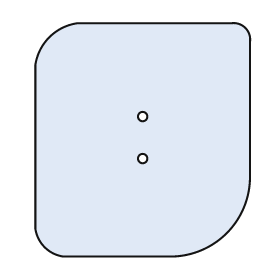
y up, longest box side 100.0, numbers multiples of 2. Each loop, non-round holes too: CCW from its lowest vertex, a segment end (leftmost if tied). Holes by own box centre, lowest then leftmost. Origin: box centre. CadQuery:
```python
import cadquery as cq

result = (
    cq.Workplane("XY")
    .moveTo(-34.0, -50.0)
    .lineTo(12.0, -50.0)
    .threePointArc((36.0, -40.0), (46.0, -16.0))
    .lineTo(46.0, 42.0)
    .threePointArc((44.0, 48.0), (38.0, 50.0))
    .lineTo(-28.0, 50.0)
    .threePointArc((-40.0, 44.0), (-46.0, 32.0))
    .lineTo(-46.0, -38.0)
    .threePointArc((-42.0, -46.0), (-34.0, -50.0))
    .close()
    .moveTo(0.0, -8.0)
    .circle(2.0)
    .moveTo(0.0, 10.0)
    .circle(2.0)
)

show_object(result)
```